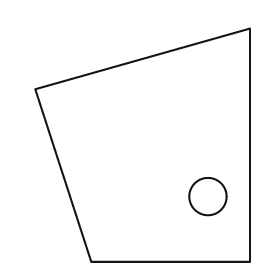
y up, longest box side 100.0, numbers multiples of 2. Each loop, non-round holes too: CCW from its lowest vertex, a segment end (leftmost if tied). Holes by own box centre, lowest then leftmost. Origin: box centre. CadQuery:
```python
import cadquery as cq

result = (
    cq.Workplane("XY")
    .moveTo(-22.0, -50.0)
    .lineTo(46.0, -50.0)
    .lineTo(46.0, 50.0)
    .lineTo(-46.0, 24.0)
    .close()
    .moveTo(28.0, -22.0)
    .circle(8.0)
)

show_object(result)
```